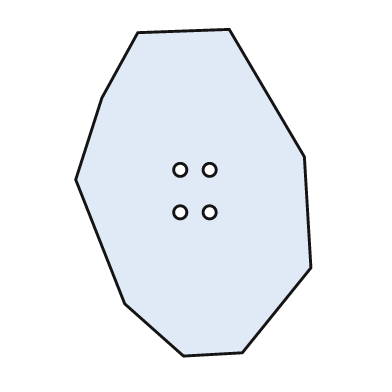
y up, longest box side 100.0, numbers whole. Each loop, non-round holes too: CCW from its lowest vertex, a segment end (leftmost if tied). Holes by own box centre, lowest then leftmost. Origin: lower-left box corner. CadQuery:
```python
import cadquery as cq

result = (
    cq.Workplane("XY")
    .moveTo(33.0, 0.0)
    .lineTo(51.0, 1.0)
    .lineTo(72.0, 27.0)
    .lineTo(70.0, 61.0)
    .lineTo(47.0, 100.0)
    .lineTo(19.0, 99.0)
    .lineTo(8.0, 79.0)
    .lineTo(0.0, 54.0)
    .lineTo(15.0, 16.0)
    .close()
    .moveTo(32.0, 44.0)
    .circle(2.0)
    .moveTo(41.0, 44.0)
    .circle(2.0)
    .moveTo(32.0, 57.0)
    .circle(2.0)
    .moveTo(41.0, 57.0)
    .circle(2.0)
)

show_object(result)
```